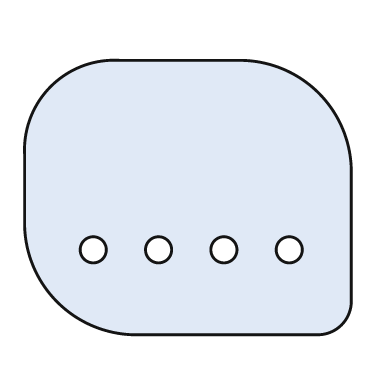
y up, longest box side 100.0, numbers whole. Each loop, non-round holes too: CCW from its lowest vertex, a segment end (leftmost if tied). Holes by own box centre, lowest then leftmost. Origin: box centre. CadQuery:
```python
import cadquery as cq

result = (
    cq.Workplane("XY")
    .moveTo(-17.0, -42.0)
    .lineTo(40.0, -42.0)
    .threePointArc((47.0, -39.0), (50.0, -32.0))
    .lineTo(50.0, 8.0)
    .threePointArc((40.0, 32.0), (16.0, 42.0))
    .lineTo(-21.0, 42.0)
    .threePointArc((-42.0, 34.0), (-50.0, 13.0))
    .lineTo(-50.0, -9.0)
    .threePointArc((-40.0, -32.0), (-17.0, -42.0))
    .close()
    .moveTo(-29.0, -16.0)
    .circle(4.0)
    .moveTo(-9.0, -16.0)
    .circle(4.0)
    .moveTo(11.0, -16.0)
    .circle(4.0)
    .moveTo(31.0, -16.0)
    .circle(4.0)
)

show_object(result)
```